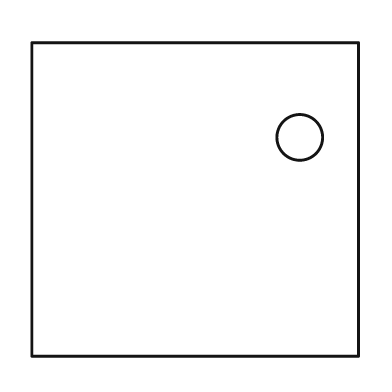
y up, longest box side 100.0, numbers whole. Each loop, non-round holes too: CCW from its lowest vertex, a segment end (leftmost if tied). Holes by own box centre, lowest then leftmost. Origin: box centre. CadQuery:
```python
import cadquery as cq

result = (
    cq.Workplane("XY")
    .moveTo(-50.0, -48.0)
    .lineTo(50.0, -48.0)
    .lineTo(50.0, 48.0)
    .lineTo(-50.0, 48.0)
    .close()
    .moveTo(32.0, 19.0)
    .circle(7.0)
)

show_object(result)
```